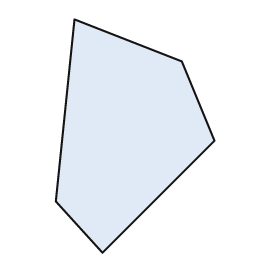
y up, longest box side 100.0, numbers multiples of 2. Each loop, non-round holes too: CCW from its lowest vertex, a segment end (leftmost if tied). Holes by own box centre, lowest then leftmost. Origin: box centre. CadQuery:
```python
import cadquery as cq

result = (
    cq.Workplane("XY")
    .moveTo(-14.0, -50.0)
    .lineTo(34.0, -2.0)
    .lineTo(20.0, 32.0)
    .lineTo(-26.0, 50.0)
    .lineTo(-34.0, -28.0)
    .close()
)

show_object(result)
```